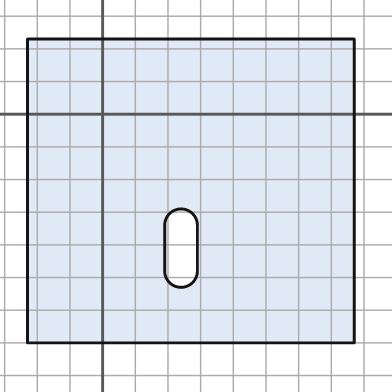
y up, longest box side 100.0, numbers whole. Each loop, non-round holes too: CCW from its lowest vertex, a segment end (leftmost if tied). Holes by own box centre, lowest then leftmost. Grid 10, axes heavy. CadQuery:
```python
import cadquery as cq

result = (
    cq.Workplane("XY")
    .moveTo(-23.0, -70.0)
    .lineTo(77.0, -70.0)
    .lineTo(77.0, 23.0)
    .lineTo(-23.0, 23.0)
    .close()
    .moveTo(19.0, -48.0)
    .threePointArc((24.0, -53.0), (29.0, -48.0))
    .lineTo(29.0, -34.0)
    .threePointArc((24.0, -29.0), (19.0, -34.0))
    .close()
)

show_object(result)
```